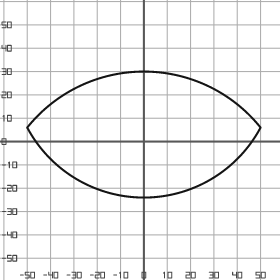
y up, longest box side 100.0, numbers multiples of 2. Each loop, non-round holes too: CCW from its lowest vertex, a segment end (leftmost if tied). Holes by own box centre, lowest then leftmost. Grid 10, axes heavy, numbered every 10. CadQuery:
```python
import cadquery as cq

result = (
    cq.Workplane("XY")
    .moveTo(-50.0, 6.0)
    .threePointArc((0.0, -24.0), (50.0, 6.0))
    .threePointArc((0.0, 30.0), (-50.0, 6.0))
    .close()
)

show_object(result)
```